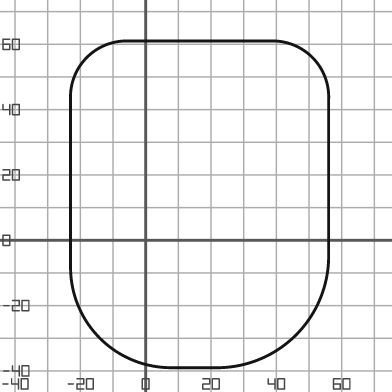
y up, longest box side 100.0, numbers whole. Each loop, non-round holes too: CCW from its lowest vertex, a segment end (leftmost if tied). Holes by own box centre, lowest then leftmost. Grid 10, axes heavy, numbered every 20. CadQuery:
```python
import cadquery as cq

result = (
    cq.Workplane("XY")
    .moveTo(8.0, -39.0)
    .lineTo(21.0, -39.0)
    .threePointArc((46.0, -29.0), (56.0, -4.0))
    .lineTo(56.0, 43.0)
    .threePointArc((51.0, 56.0), (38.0, 61.0))
    .lineTo(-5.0, 61.0)
    .threePointArc((-18.0, 56.0), (-23.0, 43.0))
    .lineTo(-23.0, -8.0)
    .threePointArc((-14.0, -30.0), (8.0, -39.0))
    .close()
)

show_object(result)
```